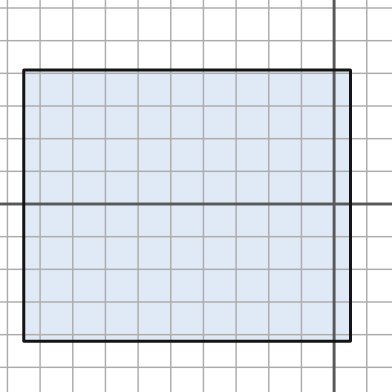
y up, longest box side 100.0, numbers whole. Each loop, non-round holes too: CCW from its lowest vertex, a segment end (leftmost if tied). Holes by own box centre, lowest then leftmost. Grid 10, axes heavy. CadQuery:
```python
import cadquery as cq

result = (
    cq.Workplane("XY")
    .moveTo(-95.0, -42.0)
    .lineTo(5.0, -42.0)
    .lineTo(5.0, 41.0)
    .lineTo(-95.0, 41.0)
    .close()
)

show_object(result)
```